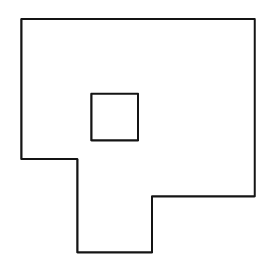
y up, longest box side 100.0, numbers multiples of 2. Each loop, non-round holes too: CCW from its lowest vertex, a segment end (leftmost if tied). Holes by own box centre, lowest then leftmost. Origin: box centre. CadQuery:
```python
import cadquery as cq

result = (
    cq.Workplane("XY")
    .moveTo(-26.0, -50.0)
    .lineTo(6.0, -50.0)
    .lineTo(6.0, -26.0)
    .lineTo(50.0, -26.0)
    .lineTo(50.0, 50.0)
    .lineTo(-50.0, 50.0)
    .lineTo(-50.0, -10.0)
    .lineTo(-26.0, -10.0)
    .close()
    .moveTo(-20.0, -2.0)
    .lineTo(0.0, -2.0)
    .lineTo(0.0, 18.0)
    .lineTo(-20.0, 18.0)
    .close()
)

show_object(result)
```